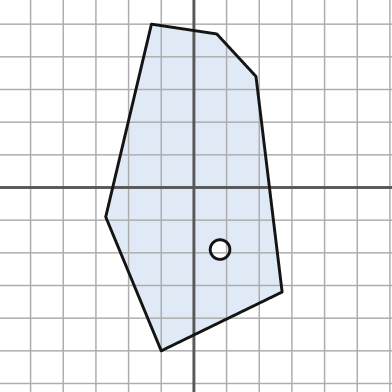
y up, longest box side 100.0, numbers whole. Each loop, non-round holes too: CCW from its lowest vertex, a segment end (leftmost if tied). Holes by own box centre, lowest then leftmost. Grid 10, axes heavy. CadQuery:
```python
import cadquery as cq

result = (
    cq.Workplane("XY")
    .moveTo(-10.0, -50.0)
    .lineTo(27.0, -32.0)
    .lineTo(19.0, 34.0)
    .lineTo(7.0, 47.0)
    .lineTo(-13.0, 50.0)
    .lineTo(-27.0, -9.0)
    .close()
    .moveTo(8.0, -19.0)
    .circle(3.0)
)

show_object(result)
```